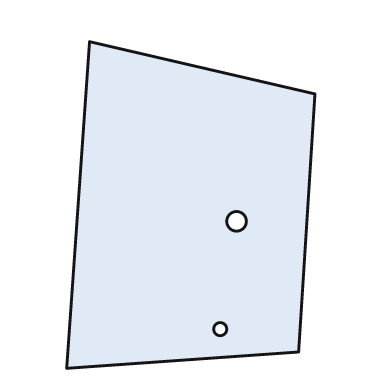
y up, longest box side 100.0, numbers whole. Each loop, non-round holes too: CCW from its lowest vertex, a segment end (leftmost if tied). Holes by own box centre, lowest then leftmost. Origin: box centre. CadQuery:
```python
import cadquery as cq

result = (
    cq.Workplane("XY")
    .moveTo(-38.0, -50.0)
    .lineTo(33.0, -45.0)
    .lineTo(38.0, 34.0)
    .lineTo(-31.0, 50.0)
    .close()
    .moveTo(9.0, -38.0)
    .circle(2.0)
    .moveTo(14.0, -5.0)
    .circle(3.0)
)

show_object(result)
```